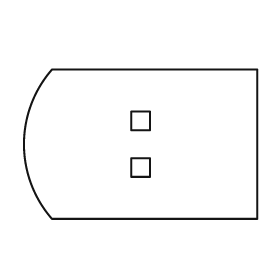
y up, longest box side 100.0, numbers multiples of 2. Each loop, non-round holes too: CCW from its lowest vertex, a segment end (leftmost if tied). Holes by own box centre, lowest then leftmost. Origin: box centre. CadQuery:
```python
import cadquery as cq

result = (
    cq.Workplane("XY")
    .moveTo(-38.0, -32.0)
    .lineTo(50.0, -32.0)
    .lineTo(50.0, 32.0)
    .lineTo(-38.0, 32.0)
    .threePointArc((-50.0, 0.0), (-38.0, -32.0))
    .close()
    .moveTo(-4.0, -14.0)
    .lineTo(4.0, -14.0)
    .lineTo(4.0, -6.0)
    .lineTo(-4.0, -6.0)
    .close()
    .moveTo(-4.0, 6.0)
    .lineTo(4.0, 6.0)
    .lineTo(4.0, 14.0)
    .lineTo(-4.0, 14.0)
    .close()
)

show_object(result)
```